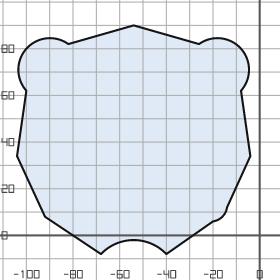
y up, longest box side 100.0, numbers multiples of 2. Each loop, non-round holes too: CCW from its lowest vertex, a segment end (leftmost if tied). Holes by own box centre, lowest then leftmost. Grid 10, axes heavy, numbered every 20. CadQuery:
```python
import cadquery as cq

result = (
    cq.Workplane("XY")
    .moveTo(-68.0, -8.0)
    .threePointArc((-54.0, -2.0), (-40.0, -8.0))
    .lineTo(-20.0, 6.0)
    .threePointArc((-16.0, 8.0), (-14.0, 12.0))
    .lineTo(-4.0, 34.0)
    .lineTo(-8.0, 62.0)
    .threePointArc((-8.0, 80.0), (-26.0, 82.0))
    .lineTo(-54.0, 90.0)
    .lineTo(-82.0, 82.0)
    .threePointArc((-100.0, 80.0), (-100.0, 62.0))
    .lineTo(-104.0, 34.0)
    .lineTo(-92.0, 8.0)
    .close()
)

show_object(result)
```